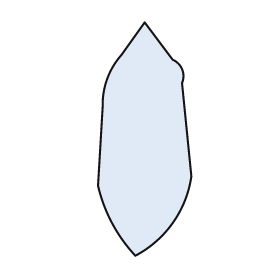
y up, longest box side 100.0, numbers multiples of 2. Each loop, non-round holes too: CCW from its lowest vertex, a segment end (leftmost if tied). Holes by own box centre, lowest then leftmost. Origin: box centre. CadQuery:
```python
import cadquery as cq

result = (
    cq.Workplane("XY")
    .moveTo(-4.0, -50.0)
    .threePointArc((12.0, -36.0), (20.0, -16.0))
    .lineTo(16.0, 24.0)
    .threePointArc((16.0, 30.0), (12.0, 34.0))
    .lineTo(0.0, 50.0)
    .lineTo(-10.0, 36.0)
    .threePointArc((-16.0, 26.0), (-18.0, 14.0))
    .lineTo(-20.0, -20.0)
    .threePointArc((-14.0, -36.0), (-4.0, -50.0))
    .close()
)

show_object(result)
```